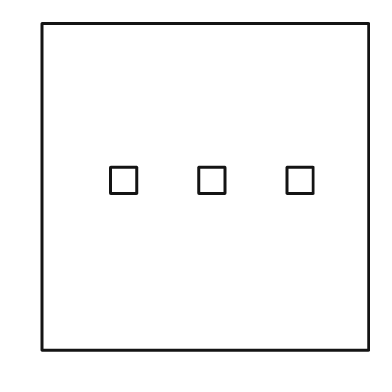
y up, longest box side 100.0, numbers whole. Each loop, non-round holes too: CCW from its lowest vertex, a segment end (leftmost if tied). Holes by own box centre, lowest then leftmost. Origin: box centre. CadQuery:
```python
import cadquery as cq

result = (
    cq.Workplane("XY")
    .moveTo(-50.0, -50.0)
    .lineTo(50.0, -50.0)
    .lineTo(50.0, 50.0)
    .lineTo(-50.0, 50.0)
    .close()
    .moveTo(-29.0, -2.0)
    .lineTo(-21.0, -2.0)
    .lineTo(-21.0, 6.0)
    .lineTo(-29.0, 6.0)
    .close()
    .moveTo(-2.0, -2.0)
    .lineTo(6.0, -2.0)
    .lineTo(6.0, 6.0)
    .lineTo(-2.0, 6.0)
    .close()
    .moveTo(25.0, -2.0)
    .lineTo(33.0, -2.0)
    .lineTo(33.0, 6.0)
    .lineTo(25.0, 6.0)
    .close()
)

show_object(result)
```